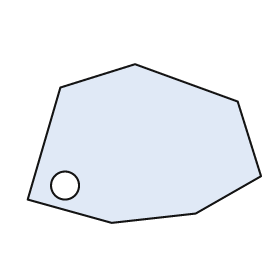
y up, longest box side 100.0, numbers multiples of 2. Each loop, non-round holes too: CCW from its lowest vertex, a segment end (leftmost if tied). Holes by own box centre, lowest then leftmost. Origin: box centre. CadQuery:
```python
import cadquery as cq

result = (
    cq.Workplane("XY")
    .moveTo(-14.0, -34.0)
    .lineTo(22.0, -30.0)
    .lineTo(50.0, -14.0)
    .lineTo(40.0, 18.0)
    .lineTo(-4.0, 34.0)
    .lineTo(-36.0, 24.0)
    .lineTo(-50.0, -24.0)
    .close()
    .moveTo(-34.0, -18.0)
    .circle(6.0)
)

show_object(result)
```